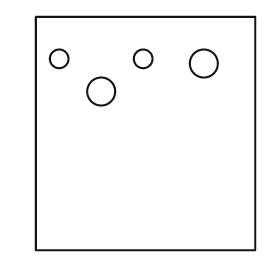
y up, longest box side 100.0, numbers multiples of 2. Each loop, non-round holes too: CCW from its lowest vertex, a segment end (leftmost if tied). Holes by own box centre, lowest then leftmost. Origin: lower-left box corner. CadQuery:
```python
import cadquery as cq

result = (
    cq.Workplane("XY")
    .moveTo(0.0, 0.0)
    .lineTo(94.0, 0.0)
    .lineTo(94.0, 100.0)
    .lineTo(0.0, 100.0)
    .close()
    .moveTo(28.0, 68.0)
    .circle(6.0)
    .moveTo(72.0, 80.0)
    .circle(6.0)
    .moveTo(10.0, 82.0)
    .circle(4.0)
    .moveTo(46.0, 82.0)
    .circle(4.0)
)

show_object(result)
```